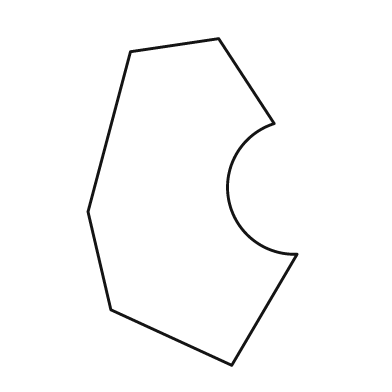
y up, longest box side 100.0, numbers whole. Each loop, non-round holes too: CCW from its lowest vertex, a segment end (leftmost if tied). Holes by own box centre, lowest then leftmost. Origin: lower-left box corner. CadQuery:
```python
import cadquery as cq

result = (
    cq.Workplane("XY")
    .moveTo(44.0, 0.0)
    .lineTo(64.0, 34.0)
    .threePointArc((43.0, 51.0), (57.0, 74.0))
    .lineTo(40.0, 100.0)
    .lineTo(13.0, 96.0)
    .lineTo(0.0, 47.0)
    .lineTo(7.0, 17.0)
    .close()
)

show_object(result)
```